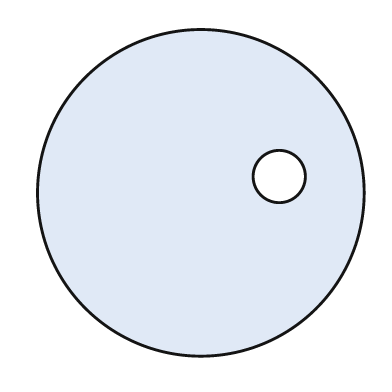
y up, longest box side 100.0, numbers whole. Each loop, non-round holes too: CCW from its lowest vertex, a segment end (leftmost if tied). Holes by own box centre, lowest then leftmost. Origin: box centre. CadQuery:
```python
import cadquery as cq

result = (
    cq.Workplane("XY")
    .moveTo(0.0, 0.0)
    .circle(50.0)
    .moveTo(24.0, 5.0)
    .circle(8.0)
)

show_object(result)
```